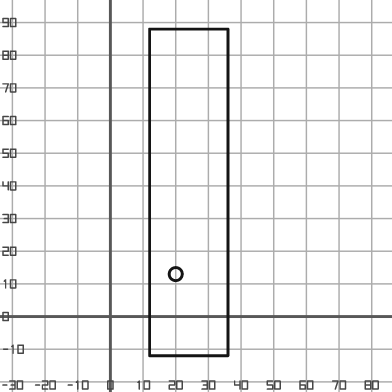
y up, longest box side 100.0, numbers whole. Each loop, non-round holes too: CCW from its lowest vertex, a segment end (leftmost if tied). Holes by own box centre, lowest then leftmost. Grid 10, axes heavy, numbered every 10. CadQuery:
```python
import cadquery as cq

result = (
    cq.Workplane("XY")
    .moveTo(12.0, -12.0)
    .lineTo(36.0, -12.0)
    .lineTo(36.0, 88.0)
    .lineTo(12.0, 88.0)
    .close()
    .moveTo(20.0, 13.0)
    .circle(2.0)
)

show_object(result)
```